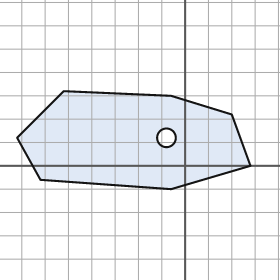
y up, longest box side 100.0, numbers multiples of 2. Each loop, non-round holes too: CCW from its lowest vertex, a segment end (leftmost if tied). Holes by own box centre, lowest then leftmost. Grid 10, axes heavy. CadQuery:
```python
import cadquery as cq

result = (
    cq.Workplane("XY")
    .moveTo(-6.0, -10.0)
    .lineTo(28.0, 0.0)
    .lineTo(20.0, 22.0)
    .lineTo(-6.0, 30.0)
    .lineTo(-52.0, 32.0)
    .lineTo(-72.0, 12.0)
    .lineTo(-62.0, -6.0)
    .close()
    .moveTo(-8.0, 12.0)
    .circle(4.0)
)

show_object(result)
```